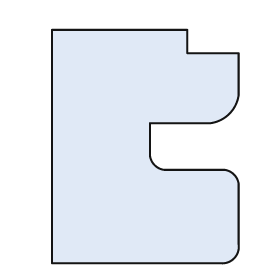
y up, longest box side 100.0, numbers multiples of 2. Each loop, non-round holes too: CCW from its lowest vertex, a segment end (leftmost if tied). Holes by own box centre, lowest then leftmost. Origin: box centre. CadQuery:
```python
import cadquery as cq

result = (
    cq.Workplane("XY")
    .moveTo(-40.0, -50.0)
    .lineTo(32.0, -50.0)
    .threePointArc((38.0, -48.0), (40.0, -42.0))
    .lineTo(40.0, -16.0)
    .threePointArc((38.0, -12.0), (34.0, -10.0))
    .lineTo(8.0, -10.0)
    .threePointArc((4.0, -8.0), (2.0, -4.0))
    .lineTo(2.0, 10.0)
    .lineTo(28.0, 10.0)
    .threePointArc((36.0, 14.0), (40.0, 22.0))
    .lineTo(40.0, 40.0)
    .lineTo(18.0, 40.0)
    .lineTo(18.0, 50.0)
    .lineTo(-40.0, 50.0)
    .close()
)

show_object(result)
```